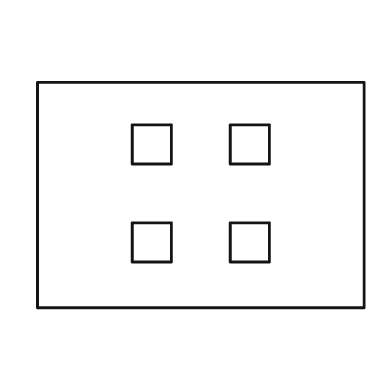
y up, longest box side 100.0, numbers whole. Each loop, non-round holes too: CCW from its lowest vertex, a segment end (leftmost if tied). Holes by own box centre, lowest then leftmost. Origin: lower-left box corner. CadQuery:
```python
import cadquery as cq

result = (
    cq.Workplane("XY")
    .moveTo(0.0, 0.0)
    .lineTo(100.0, 0.0)
    .lineTo(100.0, 69.0)
    .lineTo(0.0, 69.0)
    .close()
    .moveTo(29.0, 14.0)
    .lineTo(41.0, 14.0)
    .lineTo(41.0, 26.0)
    .lineTo(29.0, 26.0)
    .close()
    .moveTo(59.0, 14.0)
    .lineTo(71.0, 14.0)
    .lineTo(71.0, 26.0)
    .lineTo(59.0, 26.0)
    .close()
    .moveTo(29.0, 44.0)
    .lineTo(41.0, 44.0)
    .lineTo(41.0, 56.0)
    .lineTo(29.0, 56.0)
    .close()
    .moveTo(59.0, 44.0)
    .lineTo(71.0, 44.0)
    .lineTo(71.0, 56.0)
    .lineTo(59.0, 56.0)
    .close()
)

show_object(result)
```